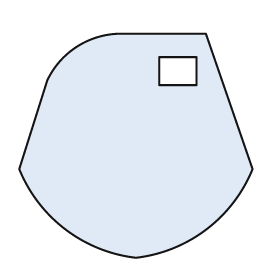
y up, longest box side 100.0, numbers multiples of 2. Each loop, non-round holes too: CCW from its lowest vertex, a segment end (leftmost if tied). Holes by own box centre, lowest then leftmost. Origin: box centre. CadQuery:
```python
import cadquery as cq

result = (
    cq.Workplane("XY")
    .moveTo(0.0, -48.0)
    .threePointArc((30.0, -36.0), (50.0, -10.0))
    .lineTo(30.0, 48.0)
    .lineTo(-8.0, 48.0)
    .threePointArc((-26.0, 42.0), (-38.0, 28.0))
    .lineTo(-50.0, -10.0)
    .threePointArc((-30.0, -36.0), (0.0, -48.0))
    .close()
    .moveTo(10.0, 26.0)
    .lineTo(26.0, 26.0)
    .lineTo(26.0, 38.0)
    .lineTo(10.0, 38.0)
    .close()
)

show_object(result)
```